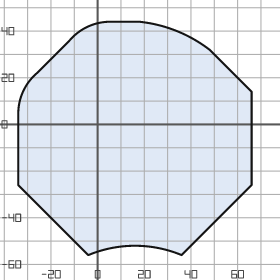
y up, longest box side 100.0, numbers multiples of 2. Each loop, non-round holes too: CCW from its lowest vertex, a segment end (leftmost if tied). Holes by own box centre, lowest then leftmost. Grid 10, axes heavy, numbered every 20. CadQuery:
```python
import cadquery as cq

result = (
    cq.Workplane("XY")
    .moveTo(-4.0, -56.0)
    .threePointArc((16.0, -52.0), (36.0, -56.0))
    .lineTo(66.0, -26.0)
    .lineTo(66.0, 14.0)
    .lineTo(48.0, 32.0)
    .threePointArc((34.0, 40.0), (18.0, 44.0))
    .lineTo(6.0, 44.0)
    .threePointArc((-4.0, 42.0), (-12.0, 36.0))
    .lineTo(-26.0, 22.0)
    .threePointArc((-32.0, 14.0), (-34.0, 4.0))
    .lineTo(-34.0, -26.0)
    .close()
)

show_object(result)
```